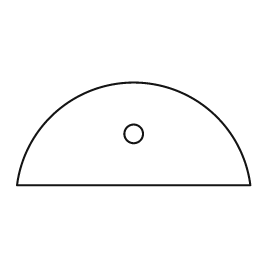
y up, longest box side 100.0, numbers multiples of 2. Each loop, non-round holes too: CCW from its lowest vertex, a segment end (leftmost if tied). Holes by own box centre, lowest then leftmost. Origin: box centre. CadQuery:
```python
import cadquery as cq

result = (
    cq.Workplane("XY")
    .moveTo(-50.0, -22.0)
    .lineTo(50.0, -22.0)
    .threePointArc((0.0, 22.0), (-50.0, -22.0))
    .close()
    .moveTo(0.0, 0.0)
    .circle(4.0)
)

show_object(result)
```